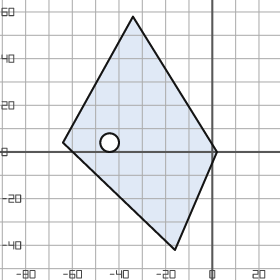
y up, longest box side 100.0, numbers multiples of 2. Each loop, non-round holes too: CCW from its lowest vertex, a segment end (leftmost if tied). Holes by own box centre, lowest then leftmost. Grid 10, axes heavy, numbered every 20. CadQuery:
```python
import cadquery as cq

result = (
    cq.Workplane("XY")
    .moveTo(-16.0, -42.0)
    .lineTo(2.0, 0.0)
    .lineTo(-34.0, 58.0)
    .lineTo(-64.0, 4.0)
    .close()
    .moveTo(-44.0, 4.0)
    .circle(4.0)
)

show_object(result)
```